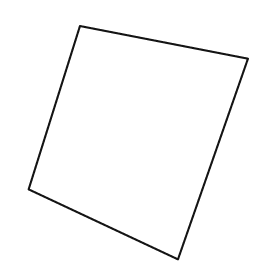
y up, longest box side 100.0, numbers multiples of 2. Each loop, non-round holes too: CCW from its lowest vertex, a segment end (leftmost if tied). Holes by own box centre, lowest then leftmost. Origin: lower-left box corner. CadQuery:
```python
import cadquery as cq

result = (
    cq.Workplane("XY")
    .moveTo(64.0, 0.0)
    .lineTo(94.0, 86.0)
    .lineTo(22.0, 100.0)
    .lineTo(0.0, 30.0)
    .close()
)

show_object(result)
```